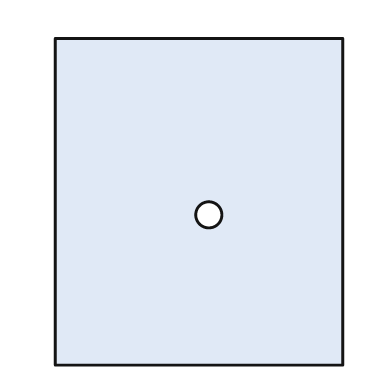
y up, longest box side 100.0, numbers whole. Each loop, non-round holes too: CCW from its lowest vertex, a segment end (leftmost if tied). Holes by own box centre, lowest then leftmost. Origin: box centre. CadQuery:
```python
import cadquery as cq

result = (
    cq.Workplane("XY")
    .moveTo(-44.0, -50.0)
    .lineTo(44.0, -50.0)
    .lineTo(44.0, 50.0)
    .lineTo(-44.0, 50.0)
    .close()
    .moveTo(3.0, -4.0)
    .circle(4.0)
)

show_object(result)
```